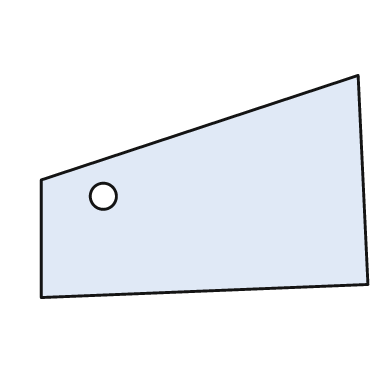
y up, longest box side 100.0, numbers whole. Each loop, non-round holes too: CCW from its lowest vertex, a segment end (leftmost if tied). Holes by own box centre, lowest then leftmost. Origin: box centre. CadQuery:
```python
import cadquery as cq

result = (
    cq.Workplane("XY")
    .moveTo(-50.0, -34.0)
    .lineTo(50.0, -30.0)
    .lineTo(47.0, 34.0)
    .lineTo(-50.0, 2.0)
    .close()
    .moveTo(-31.0, -3.0)
    .circle(4.0)
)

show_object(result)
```